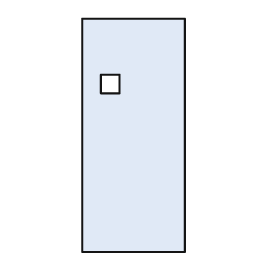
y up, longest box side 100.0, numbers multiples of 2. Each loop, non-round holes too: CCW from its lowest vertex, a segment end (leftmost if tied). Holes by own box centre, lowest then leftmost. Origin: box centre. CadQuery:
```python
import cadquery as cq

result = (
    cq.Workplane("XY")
    .moveTo(-22.0, -50.0)
    .lineTo(22.0, -50.0)
    .lineTo(22.0, 50.0)
    .lineTo(-22.0, 50.0)
    .close()
    .moveTo(-14.0, 18.0)
    .lineTo(-6.0, 18.0)
    .lineTo(-6.0, 26.0)
    .lineTo(-14.0, 26.0)
    .close()
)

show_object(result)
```